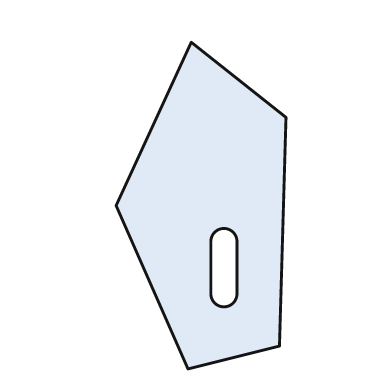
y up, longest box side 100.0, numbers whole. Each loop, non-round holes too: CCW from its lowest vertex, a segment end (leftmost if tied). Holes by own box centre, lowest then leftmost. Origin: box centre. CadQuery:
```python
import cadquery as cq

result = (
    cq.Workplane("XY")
    .moveTo(-4.0, -50.0)
    .lineTo(24.0, -43.0)
    .lineTo(26.0, 27.0)
    .lineTo(-3.0, 50.0)
    .lineTo(-26.0, 0.0)
    .close()
    .moveTo(3.0, -27.0)
    .threePointArc((7.0, -31.0), (11.0, -27.0))
    .lineTo(11.0, -11.0)
    .threePointArc((7.0, -7.0), (3.0, -11.0))
    .close()
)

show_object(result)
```